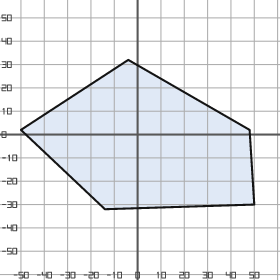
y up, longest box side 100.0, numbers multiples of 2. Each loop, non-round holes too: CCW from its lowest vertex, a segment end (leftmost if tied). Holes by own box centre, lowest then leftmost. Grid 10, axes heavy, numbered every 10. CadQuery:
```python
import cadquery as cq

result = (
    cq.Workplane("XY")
    .moveTo(-14.0, -32.0)
    .lineTo(50.0, -30.0)
    .lineTo(48.0, 2.0)
    .lineTo(-4.0, 32.0)
    .lineTo(-50.0, 2.0)
    .close()
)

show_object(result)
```